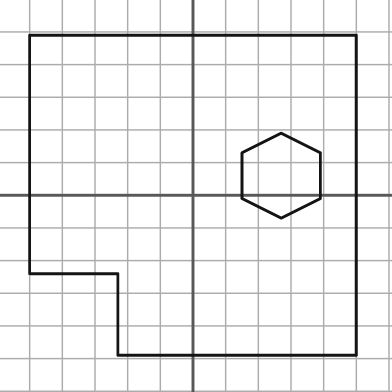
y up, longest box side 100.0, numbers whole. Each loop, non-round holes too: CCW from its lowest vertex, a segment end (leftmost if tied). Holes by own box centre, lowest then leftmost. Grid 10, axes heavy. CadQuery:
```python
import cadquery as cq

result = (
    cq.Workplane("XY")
    .moveTo(-23.0, -49.0)
    .lineTo(50.0, -49.0)
    .lineTo(50.0, 49.0)
    .lineTo(-50.0, 49.0)
    .lineTo(-50.0, -24.0)
    .lineTo(-23.0, -24.0)
    .close()
    .moveTo(27.0, -7.0)
    .lineTo(39.0, -1.0)
    .lineTo(39.0, 13.0)
    .lineTo(27.0, 19.0)
    .lineTo(15.0, 13.0)
    .lineTo(15.0, -1.0)
    .close()
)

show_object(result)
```